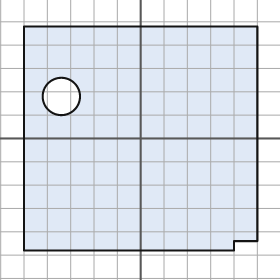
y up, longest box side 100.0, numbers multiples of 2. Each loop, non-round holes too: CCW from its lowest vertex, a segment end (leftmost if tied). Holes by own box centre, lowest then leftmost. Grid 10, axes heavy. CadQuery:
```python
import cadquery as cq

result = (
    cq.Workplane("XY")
    .moveTo(-50.0, -48.0)
    .lineTo(40.0, -48.0)
    .lineTo(40.0, -44.0)
    .lineTo(50.0, -44.0)
    .lineTo(50.0, 48.0)
    .lineTo(-50.0, 48.0)
    .close()
    .moveTo(-34.0, 18.0)
    .circle(8.0)
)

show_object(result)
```